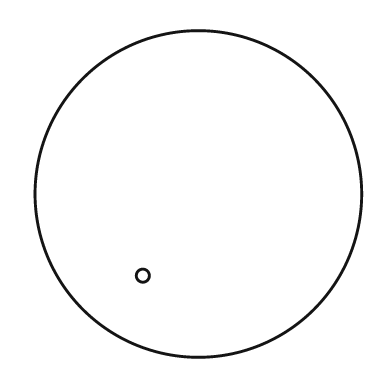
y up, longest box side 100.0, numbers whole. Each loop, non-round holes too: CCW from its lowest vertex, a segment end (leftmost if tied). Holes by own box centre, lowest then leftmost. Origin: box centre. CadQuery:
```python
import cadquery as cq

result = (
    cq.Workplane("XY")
    .moveTo(0.0, 0.0)
    .circle(50.0)
    .moveTo(-17.0, -25.0)
    .circle(2.0)
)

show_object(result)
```